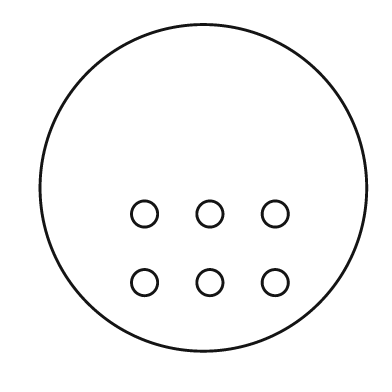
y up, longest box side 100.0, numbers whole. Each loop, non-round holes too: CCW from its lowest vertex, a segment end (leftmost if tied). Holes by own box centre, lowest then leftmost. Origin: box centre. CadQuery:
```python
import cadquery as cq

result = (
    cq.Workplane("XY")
    .moveTo(0.0, 0.0)
    .circle(50.0)
    .moveTo(-18.0, -29.0)
    .circle(4.0)
    .moveTo(2.0, -29.0)
    .circle(4.0)
    .moveTo(22.0, -29.0)
    .circle(4.0)
    .moveTo(-18.0, -8.0)
    .circle(4.0)
    .moveTo(2.0, -8.0)
    .circle(4.0)
    .moveTo(22.0, -8.0)
    .circle(4.0)
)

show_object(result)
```